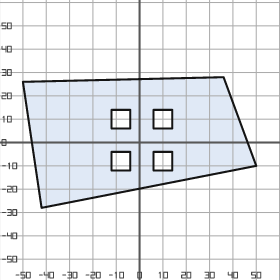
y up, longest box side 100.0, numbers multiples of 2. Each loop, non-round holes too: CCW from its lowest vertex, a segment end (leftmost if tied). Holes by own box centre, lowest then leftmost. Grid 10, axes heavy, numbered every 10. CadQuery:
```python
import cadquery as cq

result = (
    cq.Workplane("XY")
    .moveTo(-42.0, -28.0)
    .lineTo(50.0, -10.0)
    .lineTo(36.0, 28.0)
    .lineTo(-50.0, 26.0)
    .close()
    .moveTo(-12.0, -12.0)
    .lineTo(-4.0, -12.0)
    .lineTo(-4.0, -4.0)
    .lineTo(-12.0, -4.0)
    .close()
    .moveTo(6.0, -12.0)
    .lineTo(14.0, -12.0)
    .lineTo(14.0, -4.0)
    .lineTo(6.0, -4.0)
    .close()
    .moveTo(-12.0, 6.0)
    .lineTo(-4.0, 6.0)
    .lineTo(-4.0, 14.0)
    .lineTo(-12.0, 14.0)
    .close()
    .moveTo(6.0, 6.0)
    .lineTo(14.0, 6.0)
    .lineTo(14.0, 14.0)
    .lineTo(6.0, 14.0)
    .close()
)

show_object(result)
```